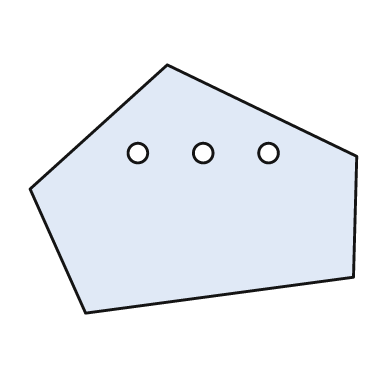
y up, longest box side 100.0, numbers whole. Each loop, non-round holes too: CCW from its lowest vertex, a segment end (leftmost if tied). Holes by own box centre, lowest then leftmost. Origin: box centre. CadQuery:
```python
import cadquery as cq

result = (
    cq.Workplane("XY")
    .moveTo(-33.0, -38.0)
    .lineTo(49.0, -27.0)
    .lineTo(50.0, 10.0)
    .lineTo(-8.0, 38.0)
    .lineTo(-50.0, 0.0)
    .close()
    .moveTo(-17.0, 11.0)
    .circle(3.0)
    .moveTo(3.0, 11.0)
    .circle(3.0)
    .moveTo(23.0, 11.0)
    .circle(3.0)
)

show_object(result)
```